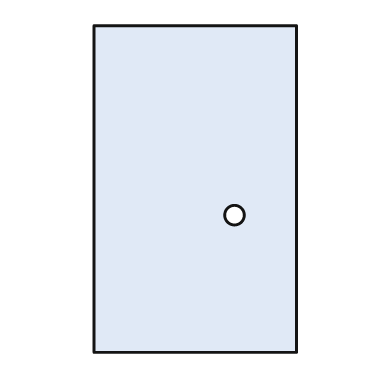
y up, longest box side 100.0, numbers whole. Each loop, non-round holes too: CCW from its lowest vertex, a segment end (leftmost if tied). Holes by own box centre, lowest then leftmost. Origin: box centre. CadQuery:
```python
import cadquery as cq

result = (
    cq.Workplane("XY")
    .moveTo(-31.0, -50.0)
    .lineTo(31.0, -50.0)
    .lineTo(31.0, 50.0)
    .lineTo(-31.0, 50.0)
    .close()
    .moveTo(12.0, -8.0)
    .circle(3.0)
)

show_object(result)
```